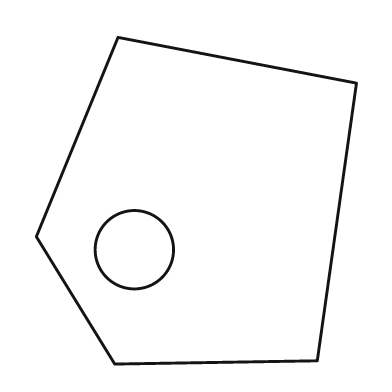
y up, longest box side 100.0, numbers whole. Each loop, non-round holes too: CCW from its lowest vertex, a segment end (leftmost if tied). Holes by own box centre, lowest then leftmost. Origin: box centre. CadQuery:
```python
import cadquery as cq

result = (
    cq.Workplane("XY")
    .moveTo(-25.0, -50.0)
    .lineTo(37.0, -49.0)
    .lineTo(49.0, 36.0)
    .lineTo(-24.0, 50.0)
    .lineTo(-49.0, -11.0)
    .close()
    .moveTo(-19.0, -15.0)
    .circle(12.0)
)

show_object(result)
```